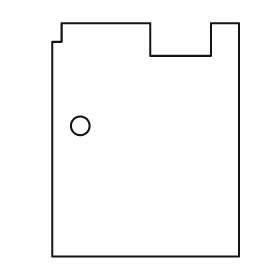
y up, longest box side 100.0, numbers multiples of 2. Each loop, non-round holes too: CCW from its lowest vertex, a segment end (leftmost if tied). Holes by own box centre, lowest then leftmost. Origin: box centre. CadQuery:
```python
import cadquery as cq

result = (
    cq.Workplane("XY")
    .moveTo(-40.0, -50.0)
    .lineTo(40.0, -50.0)
    .lineTo(40.0, 50.0)
    .lineTo(28.0, 50.0)
    .lineTo(28.0, 36.0)
    .lineTo(2.0, 36.0)
    .lineTo(2.0, 50.0)
    .lineTo(-36.0, 50.0)
    .lineTo(-36.0, 42.0)
    .lineTo(-40.0, 42.0)
    .close()
    .moveTo(-28.0, 6.0)
    .circle(4.0)
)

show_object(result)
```